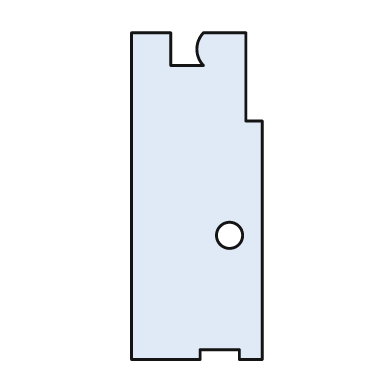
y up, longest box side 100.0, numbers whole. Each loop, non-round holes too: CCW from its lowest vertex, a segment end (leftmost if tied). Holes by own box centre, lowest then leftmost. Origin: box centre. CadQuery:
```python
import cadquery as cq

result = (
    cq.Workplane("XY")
    .moveTo(-20.0, -50.0)
    .lineTo(1.0, -50.0)
    .lineTo(1.0, -47.0)
    .lineTo(13.0, -47.0)
    .lineTo(13.0, -50.0)
    .lineTo(20.0, -50.0)
    .lineTo(20.0, 23.0)
    .lineTo(15.0, 23.0)
    .lineTo(15.0, 50.0)
    .lineTo(2.0, 50.0)
    .threePointArc((0.0, 45.0), (2.0, 40.0))
    .lineTo(-8.0, 40.0)
    .lineTo(-8.0, 50.0)
    .lineTo(-20.0, 50.0)
    .close()
    .moveTo(10.0, -12.0)
    .circle(4.0)
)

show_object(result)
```